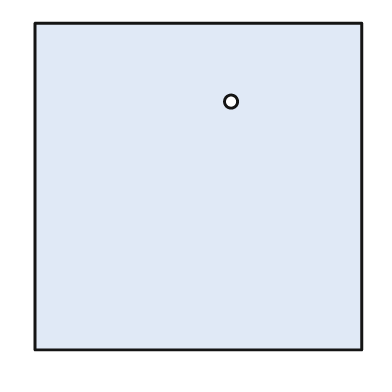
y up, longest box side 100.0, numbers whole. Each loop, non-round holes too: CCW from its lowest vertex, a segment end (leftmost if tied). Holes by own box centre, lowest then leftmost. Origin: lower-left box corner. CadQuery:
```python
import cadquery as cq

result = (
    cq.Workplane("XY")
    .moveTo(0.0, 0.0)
    .lineTo(100.0, 0.0)
    .lineTo(100.0, 100.0)
    .lineTo(0.0, 100.0)
    .close()
    .moveTo(60.0, 76.0)
    .circle(2.0)
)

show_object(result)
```